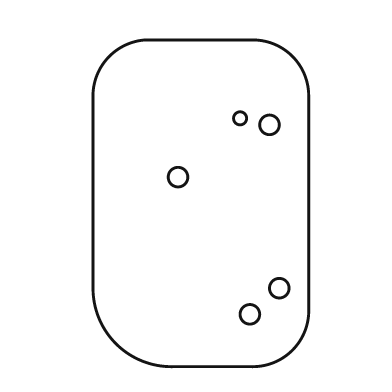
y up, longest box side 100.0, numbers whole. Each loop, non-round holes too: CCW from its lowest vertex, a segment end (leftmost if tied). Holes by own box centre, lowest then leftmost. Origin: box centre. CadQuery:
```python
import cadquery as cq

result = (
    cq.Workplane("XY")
    .moveTo(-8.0, -50.0)
    .lineTo(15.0, -50.0)
    .threePointArc((28.0, -45.0), (33.0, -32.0))
    .lineTo(33.0, 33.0)
    .threePointArc((28.0, 45.0), (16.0, 50.0))
    .lineTo(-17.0, 50.0)
    .threePointArc((-28.0, 45.0), (-33.0, 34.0))
    .lineTo(-33.0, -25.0)
    .threePointArc((-26.0, -43.0), (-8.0, -50.0))
    .close()
    .moveTo(15.0, -34.0)
    .circle(3.0)
    .moveTo(24.0, -26.0)
    .circle(3.0)
    .moveTo(-7.0, 8.0)
    .circle(3.0)
    .moveTo(21.0, 24.0)
    .circle(3.0)
    .moveTo(12.0, 26.0)
    .circle(2.0)
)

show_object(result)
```